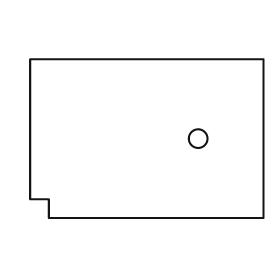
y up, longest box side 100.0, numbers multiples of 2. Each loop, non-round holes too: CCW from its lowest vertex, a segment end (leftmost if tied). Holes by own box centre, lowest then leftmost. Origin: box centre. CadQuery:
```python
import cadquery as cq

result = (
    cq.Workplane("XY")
    .moveTo(-42.0, -34.0)
    .lineTo(50.0, -34.0)
    .lineTo(50.0, 34.0)
    .lineTo(-50.0, 34.0)
    .lineTo(-50.0, -26.0)
    .lineTo(-42.0, -26.0)
    .close()
    .moveTo(22.0, 0.0)
    .circle(4.0)
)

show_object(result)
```